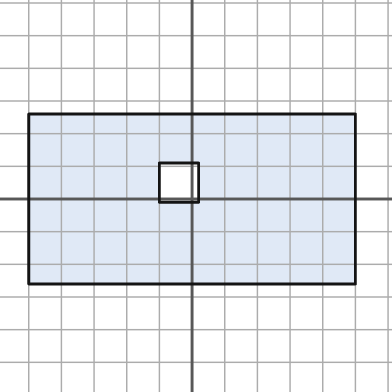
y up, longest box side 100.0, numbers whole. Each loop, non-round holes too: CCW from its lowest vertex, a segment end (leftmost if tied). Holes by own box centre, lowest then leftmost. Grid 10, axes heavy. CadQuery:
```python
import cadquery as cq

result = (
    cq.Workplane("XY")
    .moveTo(-50.0, -26.0)
    .lineTo(50.0, -26.0)
    .lineTo(50.0, 26.0)
    .lineTo(-50.0, 26.0)
    .close()
    .moveTo(-10.0, -1.0)
    .lineTo(2.0, -1.0)
    .lineTo(2.0, 11.0)
    .lineTo(-10.0, 11.0)
    .close()
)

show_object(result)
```